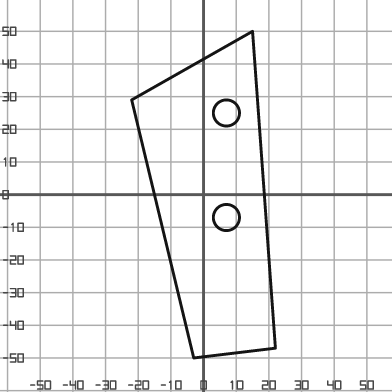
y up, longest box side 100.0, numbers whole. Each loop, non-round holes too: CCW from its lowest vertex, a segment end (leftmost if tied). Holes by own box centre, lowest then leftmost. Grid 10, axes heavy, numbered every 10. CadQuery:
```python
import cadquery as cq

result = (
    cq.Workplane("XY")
    .moveTo(-3.0, -50.0)
    .lineTo(22.0, -47.0)
    .lineTo(15.0, 50.0)
    .lineTo(-22.0, 29.0)
    .close()
    .moveTo(7.0, -7.0)
    .circle(4.0)
    .moveTo(7.0, 25.0)
    .circle(4.0)
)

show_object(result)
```